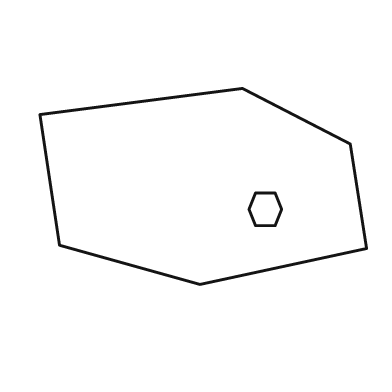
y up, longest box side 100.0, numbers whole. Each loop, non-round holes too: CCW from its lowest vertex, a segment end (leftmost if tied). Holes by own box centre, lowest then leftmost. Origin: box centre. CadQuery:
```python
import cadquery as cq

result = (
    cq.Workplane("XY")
    .moveTo(-1.0, -30.0)
    .lineTo(50.0, -19.0)
    .lineTo(45.0, 13.0)
    .lineTo(12.0, 30.0)
    .lineTo(-50.0, 22.0)
    .lineTo(-44.0, -18.0)
    .close()
    .moveTo(16.0, -12.0)
    .lineTo(22.0, -12.0)
    .lineTo(24.0, -7.0)
    .lineTo(22.0, -2.0)
    .lineTo(16.0, -2.0)
    .lineTo(14.0, -7.0)
    .close()
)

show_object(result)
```